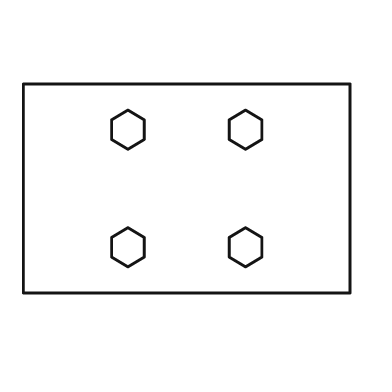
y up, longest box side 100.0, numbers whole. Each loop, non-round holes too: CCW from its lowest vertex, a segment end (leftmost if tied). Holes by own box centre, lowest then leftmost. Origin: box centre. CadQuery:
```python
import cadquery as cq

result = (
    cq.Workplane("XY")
    .moveTo(-50.0, -32.0)
    .lineTo(50.0, -32.0)
    .lineTo(50.0, 32.0)
    .lineTo(-50.0, 32.0)
    .close()
    .moveTo(-18.0, -24.0)
    .lineTo(-13.0, -21.0)
    .lineTo(-13.0, -15.0)
    .lineTo(-18.0, -12.0)
    .lineTo(-23.0, -15.0)
    .lineTo(-23.0, -21.0)
    .close()
    .moveTo(18.0, -24.0)
    .lineTo(23.0, -21.0)
    .lineTo(23.0, -15.0)
    .lineTo(18.0, -12.0)
    .lineTo(13.0, -15.0)
    .lineTo(13.0, -21.0)
    .close()
    .moveTo(-18.0, 12.0)
    .lineTo(-13.0, 15.0)
    .lineTo(-13.0, 21.0)
    .lineTo(-18.0, 24.0)
    .lineTo(-23.0, 21.0)
    .lineTo(-23.0, 15.0)
    .close()
    .moveTo(18.0, 12.0)
    .lineTo(23.0, 15.0)
    .lineTo(23.0, 21.0)
    .lineTo(18.0, 24.0)
    .lineTo(13.0, 21.0)
    .lineTo(13.0, 15.0)
    .close()
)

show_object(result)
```